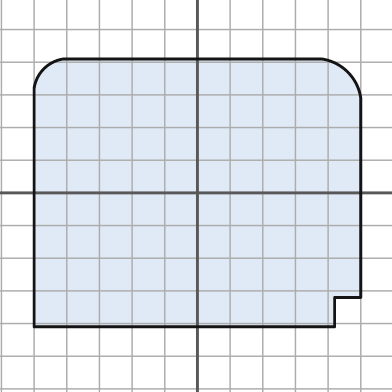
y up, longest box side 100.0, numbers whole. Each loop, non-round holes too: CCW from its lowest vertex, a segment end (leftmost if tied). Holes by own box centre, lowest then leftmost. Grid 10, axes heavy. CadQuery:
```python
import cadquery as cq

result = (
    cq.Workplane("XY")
    .moveTo(-50.0, -41.0)
    .lineTo(42.0, -41.0)
    .lineTo(42.0, -32.0)
    .lineTo(50.0, -32.0)
    .lineTo(50.0, 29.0)
    .threePointArc((46.0, 37.0), (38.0, 41.0))
    .lineTo(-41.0, 41.0)
    .threePointArc((-47.0, 38.0), (-50.0, 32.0))
    .close()
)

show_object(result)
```